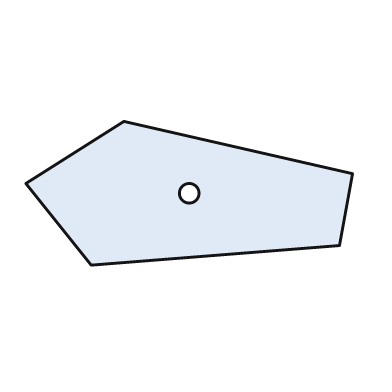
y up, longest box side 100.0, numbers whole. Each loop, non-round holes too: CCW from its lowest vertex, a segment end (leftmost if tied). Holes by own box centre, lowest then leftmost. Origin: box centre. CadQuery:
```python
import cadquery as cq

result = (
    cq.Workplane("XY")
    .moveTo(-30.0, -22.0)
    .lineTo(46.0, -16.0)
    .lineTo(50.0, 6.0)
    .lineTo(-20.0, 22.0)
    .lineTo(-50.0, 3.0)
    .close()
    .moveTo(0.0, 0.0)
    .circle(3.0)
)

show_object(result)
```